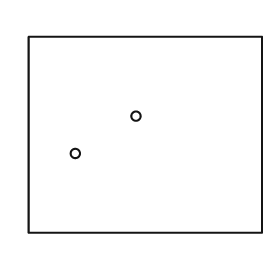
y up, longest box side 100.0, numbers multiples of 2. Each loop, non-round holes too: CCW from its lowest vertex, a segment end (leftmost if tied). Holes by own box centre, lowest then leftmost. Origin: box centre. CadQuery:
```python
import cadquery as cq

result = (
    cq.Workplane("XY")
    .moveTo(-50.0, -42.0)
    .lineTo(50.0, -42.0)
    .lineTo(50.0, 42.0)
    .lineTo(-50.0, 42.0)
    .close()
    .moveTo(-30.0, -8.0)
    .circle(2.0)
    .moveTo(-4.0, 8.0)
    .circle(2.0)
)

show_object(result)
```